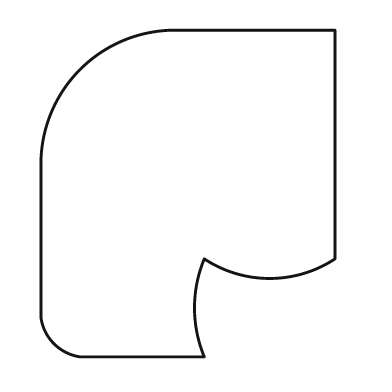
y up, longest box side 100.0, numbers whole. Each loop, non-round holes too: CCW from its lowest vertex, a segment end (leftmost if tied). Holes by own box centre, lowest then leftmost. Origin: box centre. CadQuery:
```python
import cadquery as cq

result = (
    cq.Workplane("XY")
    .moveTo(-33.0, -50.0)
    .lineTo(5.0, -50.0)
    .threePointArc((2.0, -35.0), (5.0, -20.0))
    .threePointArc((25.0, -26.0), (45.0, -20.0))
    .lineTo(45.0, 50.0)
    .lineTo(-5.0, 50.0)
    .threePointArc((-33.0, 38.0), (-45.0, 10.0))
    .lineTo(-45.0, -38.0)
    .threePointArc((-41.0, -46.0), (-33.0, -50.0))
    .close()
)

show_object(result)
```